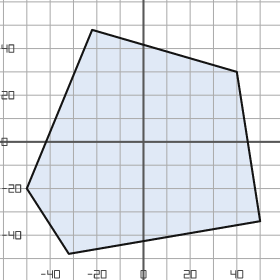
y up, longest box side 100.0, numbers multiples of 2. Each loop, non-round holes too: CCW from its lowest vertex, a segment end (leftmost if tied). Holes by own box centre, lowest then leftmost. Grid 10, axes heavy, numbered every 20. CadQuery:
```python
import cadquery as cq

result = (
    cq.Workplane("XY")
    .moveTo(-32.0, -48.0)
    .lineTo(50.0, -34.0)
    .lineTo(40.0, 30.0)
    .lineTo(-22.0, 48.0)
    .lineTo(-50.0, -20.0)
    .close()
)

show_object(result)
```